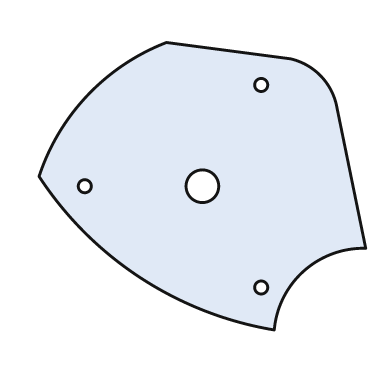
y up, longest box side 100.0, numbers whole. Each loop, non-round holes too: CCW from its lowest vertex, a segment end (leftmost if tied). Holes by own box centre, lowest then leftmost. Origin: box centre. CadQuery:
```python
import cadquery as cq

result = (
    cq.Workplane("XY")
    .moveTo(22.0, -44.0)
    .threePointArc((31.0, -26.0), (50.0, -19.0))
    .lineTo(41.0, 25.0)
    .threePointArc((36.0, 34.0), (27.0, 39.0))
    .lineTo(-11.0, 44.0)
    .threePointArc((-35.0, 28.0), (-50.0, 3.0))
    .threePointArc((-19.0, -28.0), (22.0, -44.0))
    .close()
    .moveTo(18.0, -31.0)
    .circle(2.0)
    .moveTo(-36.0, 0.0)
    .circle(2.0)
    .moveTo(0.0, 0.0)
    .circle(5.0)
    .moveTo(18.0, 31.0)
    .circle(2.0)
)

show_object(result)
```